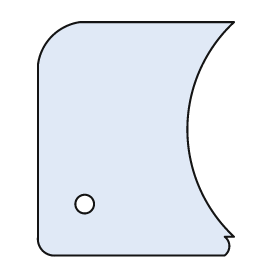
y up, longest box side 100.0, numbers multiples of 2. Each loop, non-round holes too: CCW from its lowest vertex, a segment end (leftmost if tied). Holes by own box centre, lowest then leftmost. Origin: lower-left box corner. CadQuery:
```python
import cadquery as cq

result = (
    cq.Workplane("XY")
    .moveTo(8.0, 0.0)
    .lineTo(80.0, 0.0)
    .threePointArc((82.0, 4.0), (80.0, 8.0))
    .lineTo(84.0, 8.0)
    .threePointArc((64.0, 54.0), (84.0, 100.0))
    .lineTo(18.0, 100.0)
    .threePointArc((6.0, 94.0), (0.0, 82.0))
    .lineTo(0.0, 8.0)
    .threePointArc((2.0, 2.0), (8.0, 0.0))
    .close()
    .moveTo(20.0, 22.0)
    .circle(4.0)
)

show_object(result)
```